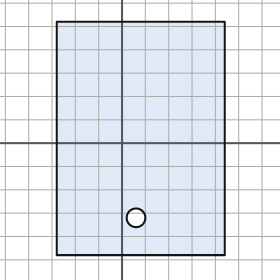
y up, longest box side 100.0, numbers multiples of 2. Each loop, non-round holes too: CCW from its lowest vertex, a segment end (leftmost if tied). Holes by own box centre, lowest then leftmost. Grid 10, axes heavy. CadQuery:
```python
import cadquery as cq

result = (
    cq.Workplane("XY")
    .moveTo(-28.0, -48.0)
    .lineTo(44.0, -48.0)
    .lineTo(44.0, 52.0)
    .lineTo(-28.0, 52.0)
    .close()
    .moveTo(6.0, -32.0)
    .circle(4.0)
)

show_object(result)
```